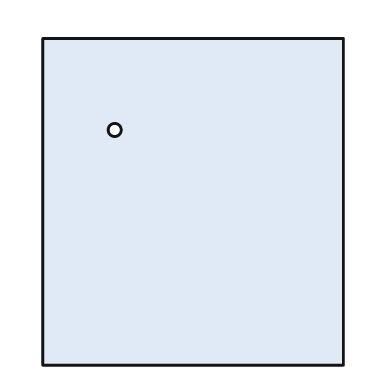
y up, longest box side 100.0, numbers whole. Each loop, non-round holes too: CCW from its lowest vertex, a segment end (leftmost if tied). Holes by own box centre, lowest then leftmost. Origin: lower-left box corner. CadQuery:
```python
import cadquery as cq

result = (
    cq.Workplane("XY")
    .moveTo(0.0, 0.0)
    .lineTo(92.0, 0.0)
    .lineTo(92.0, 100.0)
    .lineTo(0.0, 100.0)
    .close()
    .moveTo(22.0, 72.0)
    .circle(2.0)
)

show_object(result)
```